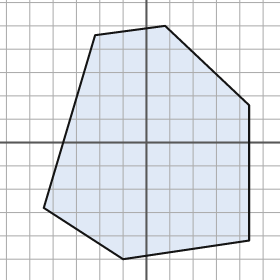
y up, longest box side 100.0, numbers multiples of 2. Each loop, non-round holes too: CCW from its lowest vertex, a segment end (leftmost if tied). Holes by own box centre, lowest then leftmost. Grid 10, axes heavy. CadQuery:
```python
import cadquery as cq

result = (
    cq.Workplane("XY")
    .moveTo(-10.0, -50.0)
    .lineTo(44.0, -42.0)
    .lineTo(44.0, 16.0)
    .lineTo(8.0, 50.0)
    .lineTo(-22.0, 46.0)
    .lineTo(-44.0, -28.0)
    .close()
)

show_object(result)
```